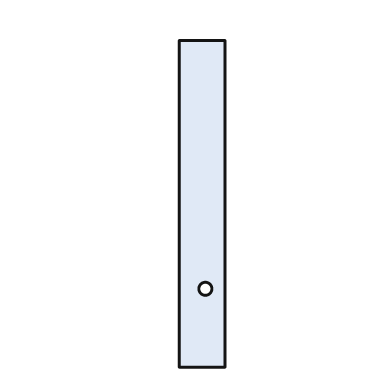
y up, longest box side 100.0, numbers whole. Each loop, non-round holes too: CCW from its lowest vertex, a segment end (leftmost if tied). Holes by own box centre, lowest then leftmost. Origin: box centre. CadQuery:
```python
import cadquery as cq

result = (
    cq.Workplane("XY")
    .moveTo(-7.0, -50.0)
    .lineTo(7.0, -50.0)
    .lineTo(7.0, 50.0)
    .lineTo(-7.0, 50.0)
    .close()
    .moveTo(1.0, -26.0)
    .circle(2.0)
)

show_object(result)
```